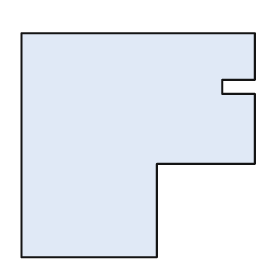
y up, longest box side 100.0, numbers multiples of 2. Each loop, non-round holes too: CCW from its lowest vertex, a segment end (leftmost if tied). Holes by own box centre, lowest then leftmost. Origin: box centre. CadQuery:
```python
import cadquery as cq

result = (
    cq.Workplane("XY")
    .moveTo(-50.0, -48.0)
    .lineTo(8.0, -48.0)
    .lineTo(8.0, -8.0)
    .lineTo(50.0, -8.0)
    .lineTo(50.0, 22.0)
    .lineTo(36.0, 22.0)
    .lineTo(36.0, 28.0)
    .lineTo(50.0, 28.0)
    .lineTo(50.0, 48.0)
    .lineTo(-50.0, 48.0)
    .close()
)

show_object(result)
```